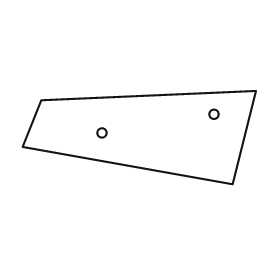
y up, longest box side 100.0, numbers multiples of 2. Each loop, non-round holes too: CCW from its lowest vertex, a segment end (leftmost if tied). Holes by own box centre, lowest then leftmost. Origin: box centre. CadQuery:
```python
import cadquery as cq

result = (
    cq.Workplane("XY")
    .moveTo(40.0, -20.0)
    .lineTo(50.0, 20.0)
    .lineTo(-42.0, 16.0)
    .lineTo(-50.0, -4.0)
    .close()
    .moveTo(-16.0, 2.0)
    .circle(2.0)
    .moveTo(32.0, 10.0)
    .circle(2.0)
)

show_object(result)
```